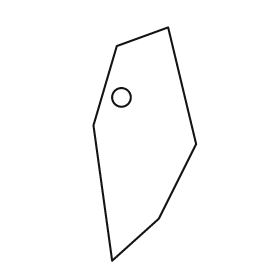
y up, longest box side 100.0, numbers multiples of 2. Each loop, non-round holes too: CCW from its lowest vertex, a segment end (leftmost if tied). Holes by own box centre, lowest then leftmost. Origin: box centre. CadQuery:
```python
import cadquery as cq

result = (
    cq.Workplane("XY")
    .moveTo(-14.0, -50.0)
    .lineTo(6.0, -32.0)
    .lineTo(22.0, 0.0)
    .lineTo(10.0, 50.0)
    .lineTo(-12.0, 42.0)
    .lineTo(-22.0, 8.0)
    .close()
    .moveTo(-10.0, 20.0)
    .circle(4.0)
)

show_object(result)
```